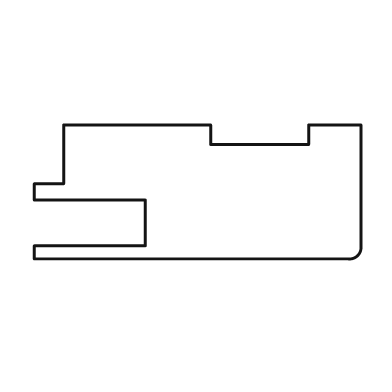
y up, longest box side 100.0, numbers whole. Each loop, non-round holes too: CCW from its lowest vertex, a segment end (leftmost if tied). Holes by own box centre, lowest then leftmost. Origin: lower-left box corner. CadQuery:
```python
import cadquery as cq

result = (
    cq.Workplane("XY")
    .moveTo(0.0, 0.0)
    .lineTo(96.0, 0.0)
    .threePointArc((99.0, 1.0), (100.0, 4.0))
    .lineTo(100.0, 41.0)
    .lineTo(84.0, 41.0)
    .lineTo(84.0, 35.0)
    .lineTo(54.0, 35.0)
    .lineTo(54.0, 41.0)
    .lineTo(9.0, 41.0)
    .lineTo(9.0, 23.0)
    .lineTo(0.0, 23.0)
    .lineTo(0.0, 18.0)
    .lineTo(34.0, 18.0)
    .lineTo(34.0, 4.0)
    .lineTo(0.0, 4.0)
    .close()
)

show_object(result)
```